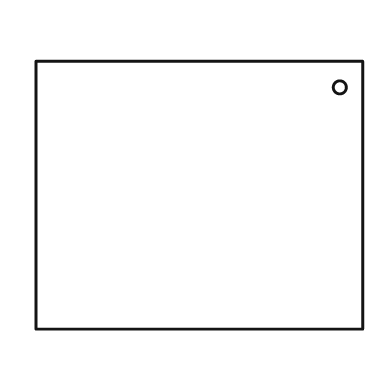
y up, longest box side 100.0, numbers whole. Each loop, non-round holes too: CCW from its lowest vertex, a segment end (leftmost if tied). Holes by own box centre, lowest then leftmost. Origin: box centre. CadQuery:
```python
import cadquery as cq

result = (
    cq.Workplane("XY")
    .moveTo(-50.0, -41.0)
    .lineTo(50.0, -41.0)
    .lineTo(50.0, 41.0)
    .lineTo(-50.0, 41.0)
    .close()
    .moveTo(43.0, 33.0)
    .circle(2.0)
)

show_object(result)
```